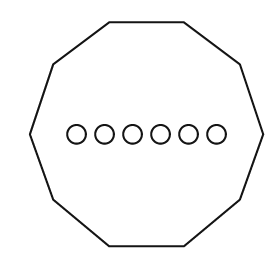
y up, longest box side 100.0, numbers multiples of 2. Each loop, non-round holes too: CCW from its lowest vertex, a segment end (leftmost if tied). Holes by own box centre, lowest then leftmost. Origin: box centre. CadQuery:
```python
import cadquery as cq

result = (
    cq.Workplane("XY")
    .moveTo(-16.0, -48.0)
    .lineTo(16.0, -48.0)
    .lineTo(40.0, -28.0)
    .lineTo(50.0, 0.0)
    .lineTo(40.0, 30.0)
    .lineTo(16.0, 48.0)
    .lineTo(-16.0, 48.0)
    .lineTo(-40.0, 30.0)
    .lineTo(-50.0, 0.0)
    .lineTo(-40.0, -28.0)
    .close()
    .moveTo(-30.0, 0.0)
    .circle(4.0)
    .moveTo(-18.0, 0.0)
    .circle(4.0)
    .moveTo(-6.0, 0.0)
    .circle(4.0)
    .moveTo(6.0, 0.0)
    .circle(4.0)
    .moveTo(18.0, 0.0)
    .circle(4.0)
    .moveTo(30.0, 0.0)
    .circle(4.0)
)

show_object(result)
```